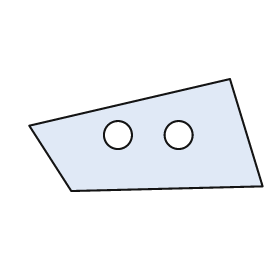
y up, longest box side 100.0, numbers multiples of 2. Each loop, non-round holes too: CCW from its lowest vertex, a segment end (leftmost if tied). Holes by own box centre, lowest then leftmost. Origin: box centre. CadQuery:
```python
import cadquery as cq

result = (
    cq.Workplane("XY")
    .moveTo(-32.0, -24.0)
    .lineTo(50.0, -22.0)
    .lineTo(36.0, 24.0)
    .lineTo(-50.0, 4.0)
    .close()
    .moveTo(-12.0, 0.0)
    .circle(6.0)
    .moveTo(14.0, 0.0)
    .circle(6.0)
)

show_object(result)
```